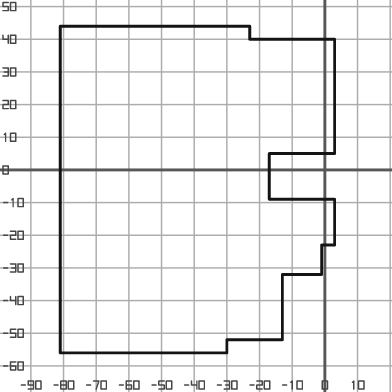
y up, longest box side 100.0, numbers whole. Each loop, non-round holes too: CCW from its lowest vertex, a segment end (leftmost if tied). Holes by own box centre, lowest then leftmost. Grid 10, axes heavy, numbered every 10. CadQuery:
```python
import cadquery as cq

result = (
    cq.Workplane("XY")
    .moveTo(-81.0, -56.0)
    .lineTo(-30.0, -56.0)
    .lineTo(-30.0, -52.0)
    .lineTo(-13.0, -52.0)
    .lineTo(-13.0, -32.0)
    .lineTo(-1.0, -32.0)
    .lineTo(-1.0, -23.0)
    .lineTo(3.0, -23.0)
    .lineTo(3.0, -9.0)
    .lineTo(-17.0, -9.0)
    .lineTo(-17.0, 5.0)
    .lineTo(3.0, 5.0)
    .lineTo(3.0, 40.0)
    .lineTo(-23.0, 40.0)
    .lineTo(-23.0, 44.0)
    .lineTo(-81.0, 44.0)
    .close()
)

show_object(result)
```